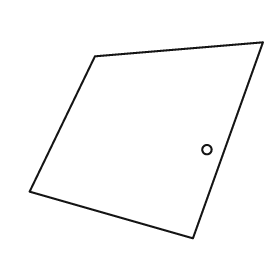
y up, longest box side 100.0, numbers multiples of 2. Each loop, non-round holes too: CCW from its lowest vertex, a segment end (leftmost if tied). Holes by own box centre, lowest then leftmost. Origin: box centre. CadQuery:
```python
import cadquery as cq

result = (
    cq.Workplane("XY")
    .moveTo(20.0, -42.0)
    .lineTo(50.0, 42.0)
    .lineTo(-22.0, 36.0)
    .lineTo(-50.0, -22.0)
    .close()
    .moveTo(26.0, -4.0)
    .circle(2.0)
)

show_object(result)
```